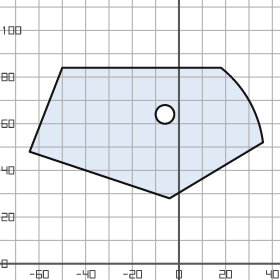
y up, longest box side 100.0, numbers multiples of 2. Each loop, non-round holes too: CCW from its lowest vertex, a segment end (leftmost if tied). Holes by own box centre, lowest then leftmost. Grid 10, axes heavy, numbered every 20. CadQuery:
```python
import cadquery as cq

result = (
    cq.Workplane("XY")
    .moveTo(-4.0, 28.0)
    .lineTo(36.0, 52.0)
    .threePointArc((30.0, 70.0), (18.0, 84.0))
    .lineTo(-50.0, 84.0)
    .lineTo(-64.0, 48.0)
    .close()
    .moveTo(-6.0, 64.0)
    .circle(4.0)
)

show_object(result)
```